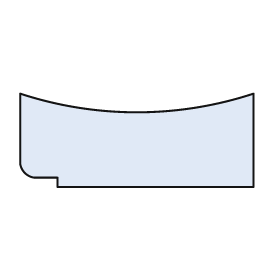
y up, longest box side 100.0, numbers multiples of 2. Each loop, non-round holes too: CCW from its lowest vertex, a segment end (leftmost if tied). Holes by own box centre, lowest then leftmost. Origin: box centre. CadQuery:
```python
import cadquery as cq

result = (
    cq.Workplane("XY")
    .moveTo(-34.0, -20.0)
    .lineTo(50.0, -20.0)
    .lineTo(50.0, 20.0)
    .threePointArc((0.0, 12.0), (-50.0, 20.0))
    .lineTo(-50.0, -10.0)
    .threePointArc((-48.0, -14.0), (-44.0, -16.0))
    .lineTo(-34.0, -16.0)
    .close()
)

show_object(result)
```